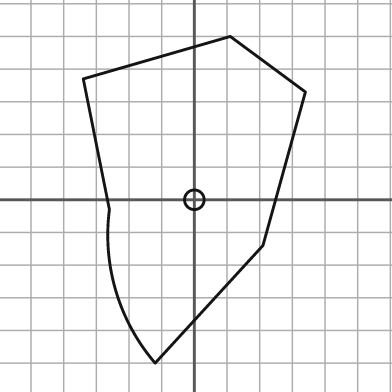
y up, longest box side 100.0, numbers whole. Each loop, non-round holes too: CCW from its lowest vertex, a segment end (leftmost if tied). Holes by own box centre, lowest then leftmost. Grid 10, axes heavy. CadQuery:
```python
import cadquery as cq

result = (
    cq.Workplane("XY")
    .moveTo(-12.0, -50.0)
    .lineTo(21.0, -14.0)
    .lineTo(34.0, 33.0)
    .lineTo(11.0, 50.0)
    .lineTo(-34.0, 37.0)
    .lineTo(-26.0, -3.0)
    .threePointArc((-24.0, -28.0), (-12.0, -50.0))
    .close()
    .moveTo(0.0, 0.0)
    .circle(3.0)
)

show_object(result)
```